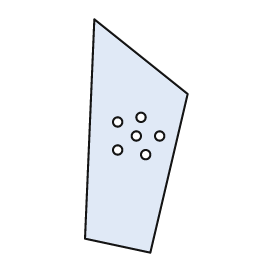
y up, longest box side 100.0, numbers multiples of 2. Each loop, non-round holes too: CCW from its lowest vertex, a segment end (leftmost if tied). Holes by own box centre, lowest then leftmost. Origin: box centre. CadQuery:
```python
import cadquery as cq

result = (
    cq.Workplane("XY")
    .moveTo(6.0, -50.0)
    .lineTo(22.0, 18.0)
    .lineTo(-18.0, 50.0)
    .lineTo(-22.0, -44.0)
    .close()
    .moveTo(4.0, -8.0)
    .circle(2.0)
    .moveTo(-8.0, -6.0)
    .circle(2.0)
    .moveTo(0.0, 0.0)
    .circle(2.0)
    .moveTo(10.0, 0.0)
    .circle(2.0)
    .moveTo(-8.0, 6.0)
    .circle(2.0)
    .moveTo(2.0, 8.0)
    .circle(2.0)
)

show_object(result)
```